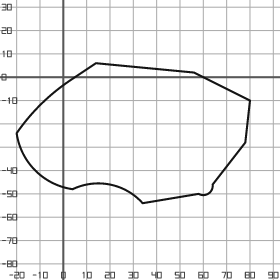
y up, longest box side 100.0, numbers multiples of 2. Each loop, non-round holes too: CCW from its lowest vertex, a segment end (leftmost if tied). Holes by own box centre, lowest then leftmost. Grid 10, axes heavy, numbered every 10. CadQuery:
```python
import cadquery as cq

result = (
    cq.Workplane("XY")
    .moveTo(34.0, -54.0)
    .lineTo(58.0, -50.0)
    .threePointArc((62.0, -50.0), (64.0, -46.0))
    .lineTo(78.0, -28.0)
    .lineTo(80.0, -10.0)
    .lineTo(56.0, 2.0)
    .lineTo(14.0, 6.0)
    .lineTo(2.0, -2.0)
    .threePointArc((-10.0, -12.0), (-20.0, -24.0))
    .threePointArc((-12.0, -40.0), (4.0, -48.0))
    .threePointArc((20.0, -46.0), (34.0, -54.0))
    .close()
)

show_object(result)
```